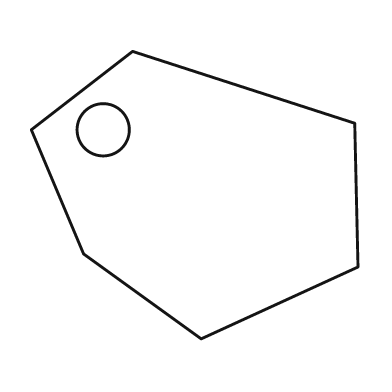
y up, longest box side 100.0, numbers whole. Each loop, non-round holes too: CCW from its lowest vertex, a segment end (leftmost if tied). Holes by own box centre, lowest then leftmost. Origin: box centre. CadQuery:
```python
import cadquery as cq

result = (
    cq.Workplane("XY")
    .moveTo(2.0, -44.0)
    .lineTo(50.0, -22.0)
    .lineTo(49.0, 22.0)
    .lineTo(-19.0, 44.0)
    .lineTo(-50.0, 20.0)
    .lineTo(-34.0, -18.0)
    .close()
    .moveTo(-28.0, 20.0)
    .circle(8.0)
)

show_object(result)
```